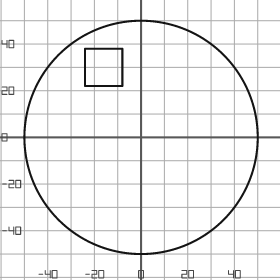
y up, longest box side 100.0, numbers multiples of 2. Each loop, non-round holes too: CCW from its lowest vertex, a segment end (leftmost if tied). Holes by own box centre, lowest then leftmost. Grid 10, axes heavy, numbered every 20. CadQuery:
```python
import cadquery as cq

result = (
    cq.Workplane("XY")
    .moveTo(0.0, 0.0)
    .circle(50.0)
    .moveTo(-24.0, 22.0)
    .lineTo(-8.0, 22.0)
    .lineTo(-8.0, 38.0)
    .lineTo(-24.0, 38.0)
    .close()
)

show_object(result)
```